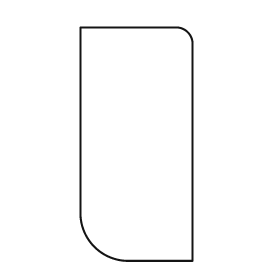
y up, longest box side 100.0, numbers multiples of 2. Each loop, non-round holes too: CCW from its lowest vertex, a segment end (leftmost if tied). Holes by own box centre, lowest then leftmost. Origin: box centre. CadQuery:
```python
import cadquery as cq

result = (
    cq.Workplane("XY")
    .moveTo(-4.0, -50.0)
    .lineTo(24.0, -50.0)
    .lineTo(24.0, 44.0)
    .threePointArc((22.0, 48.0), (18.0, 50.0))
    .lineTo(-24.0, 50.0)
    .lineTo(-24.0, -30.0)
    .threePointArc((-18.0, -44.0), (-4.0, -50.0))
    .close()
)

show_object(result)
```